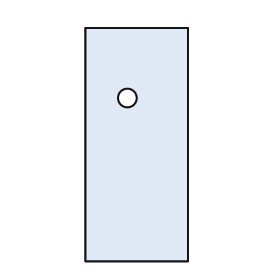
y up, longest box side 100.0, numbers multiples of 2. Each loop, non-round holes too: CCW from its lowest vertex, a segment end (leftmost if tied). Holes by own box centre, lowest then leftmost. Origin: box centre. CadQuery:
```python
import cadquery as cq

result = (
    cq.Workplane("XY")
    .moveTo(-22.0, -50.0)
    .lineTo(22.0, -50.0)
    .lineTo(22.0, 50.0)
    .lineTo(-22.0, 50.0)
    .close()
    .moveTo(-4.0, 20.0)
    .circle(4.0)
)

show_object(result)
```